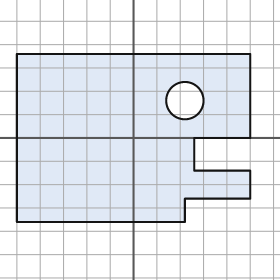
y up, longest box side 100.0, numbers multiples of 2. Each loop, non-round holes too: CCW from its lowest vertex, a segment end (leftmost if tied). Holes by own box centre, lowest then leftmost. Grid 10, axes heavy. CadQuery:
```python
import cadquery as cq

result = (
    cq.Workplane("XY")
    .moveTo(-50.0, -36.0)
    .lineTo(22.0, -36.0)
    .lineTo(22.0, -26.0)
    .lineTo(50.0, -26.0)
    .lineTo(50.0, -14.0)
    .lineTo(26.0, -14.0)
    .lineTo(26.0, 0.0)
    .lineTo(50.0, 0.0)
    .lineTo(50.0, 36.0)
    .lineTo(-50.0, 36.0)
    .close()
    .moveTo(22.0, 16.0)
    .circle(8.0)
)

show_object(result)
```